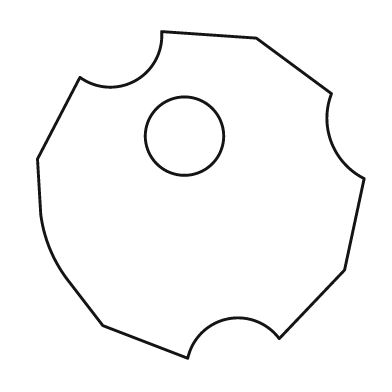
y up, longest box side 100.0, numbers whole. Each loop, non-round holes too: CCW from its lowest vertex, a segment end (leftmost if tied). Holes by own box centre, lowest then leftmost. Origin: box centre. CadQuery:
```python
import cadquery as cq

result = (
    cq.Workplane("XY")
    .moveTo(-4.0, -50.0)
    .threePointArc((8.0, -38.0), (24.0, -44.0))
    .lineTo(44.0, -23.0)
    .lineTo(50.0, 5.0)
    .threePointArc((40.0, 16.0), (40.0, 31.0))
    .lineTo(17.0, 48.0)
    .lineTo(-12.0, 50.0)
    .threePointArc((-20.0, 35.0), (-37.0, 36.0))
    .lineTo(-50.0, 11.0)
    .lineTo(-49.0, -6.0)
    .threePointArc((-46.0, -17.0), (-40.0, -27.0))
    .lineTo(-30.0, -40.0)
    .close()
    .moveTo(-5.0, 18.0)
    .circle(12.0)
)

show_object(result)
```